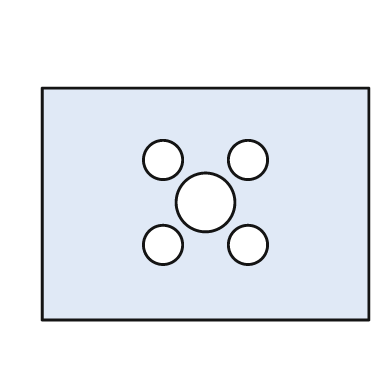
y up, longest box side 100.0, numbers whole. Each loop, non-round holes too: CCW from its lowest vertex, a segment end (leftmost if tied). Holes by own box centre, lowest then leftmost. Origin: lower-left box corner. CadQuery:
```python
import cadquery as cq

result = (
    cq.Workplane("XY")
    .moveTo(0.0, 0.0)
    .lineTo(100.0, 0.0)
    .lineTo(100.0, 71.0)
    .lineTo(0.0, 71.0)
    .close()
    .moveTo(37.0, 23.0)
    .circle(6.0)
    .moveTo(63.0, 23.0)
    .circle(6.0)
    .moveTo(50.0, 36.0)
    .circle(9.0)
    .moveTo(37.0, 49.0)
    .circle(6.0)
    .moveTo(63.0, 49.0)
    .circle(6.0)
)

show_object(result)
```